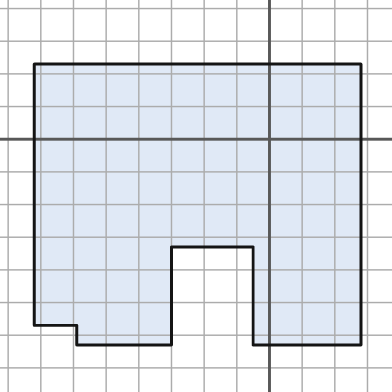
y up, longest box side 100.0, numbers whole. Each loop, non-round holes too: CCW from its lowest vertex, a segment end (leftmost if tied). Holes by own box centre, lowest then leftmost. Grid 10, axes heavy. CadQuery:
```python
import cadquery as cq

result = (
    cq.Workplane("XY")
    .moveTo(-59.0, -63.0)
    .lineTo(-30.0, -63.0)
    .lineTo(-30.0, -33.0)
    .lineTo(-5.0, -33.0)
    .lineTo(-5.0, -63.0)
    .lineTo(28.0, -63.0)
    .lineTo(28.0, 23.0)
    .lineTo(-72.0, 23.0)
    .lineTo(-72.0, -57.0)
    .lineTo(-59.0, -57.0)
    .close()
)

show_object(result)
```